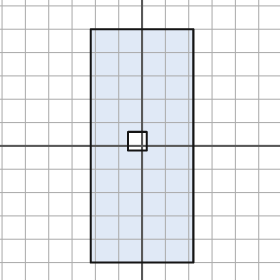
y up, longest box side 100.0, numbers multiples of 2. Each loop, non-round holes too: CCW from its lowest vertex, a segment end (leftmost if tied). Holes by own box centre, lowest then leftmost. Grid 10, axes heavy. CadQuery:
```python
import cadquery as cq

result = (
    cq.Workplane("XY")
    .moveTo(-22.0, -50.0)
    .lineTo(22.0, -50.0)
    .lineTo(22.0, 50.0)
    .lineTo(-22.0, 50.0)
    .close()
    .moveTo(-6.0, -2.0)
    .lineTo(2.0, -2.0)
    .lineTo(2.0, 6.0)
    .lineTo(-6.0, 6.0)
    .close()
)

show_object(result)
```